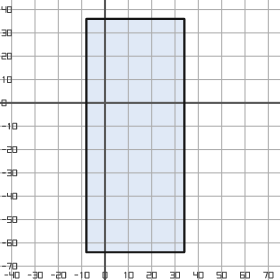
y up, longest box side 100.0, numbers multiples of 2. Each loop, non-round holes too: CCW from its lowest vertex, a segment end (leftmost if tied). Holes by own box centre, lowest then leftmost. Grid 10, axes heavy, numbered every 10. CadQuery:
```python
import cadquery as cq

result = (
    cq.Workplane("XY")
    .moveTo(-8.0, -64.0)
    .lineTo(34.0, -64.0)
    .lineTo(34.0, 36.0)
    .lineTo(-8.0, 36.0)
    .close()
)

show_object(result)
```